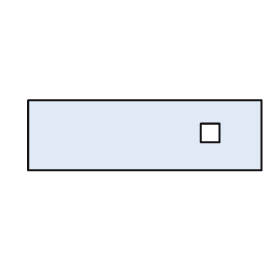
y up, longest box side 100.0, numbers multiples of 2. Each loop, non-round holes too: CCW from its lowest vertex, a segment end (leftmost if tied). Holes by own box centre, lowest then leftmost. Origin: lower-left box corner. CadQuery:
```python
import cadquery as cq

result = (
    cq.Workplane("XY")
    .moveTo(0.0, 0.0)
    .lineTo(100.0, 0.0)
    .lineTo(100.0, 30.0)
    .lineTo(0.0, 30.0)
    .close()
    .moveTo(74.0, 12.0)
    .lineTo(82.0, 12.0)
    .lineTo(82.0, 20.0)
    .lineTo(74.0, 20.0)
    .close()
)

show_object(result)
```